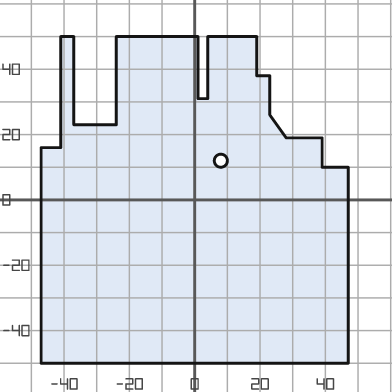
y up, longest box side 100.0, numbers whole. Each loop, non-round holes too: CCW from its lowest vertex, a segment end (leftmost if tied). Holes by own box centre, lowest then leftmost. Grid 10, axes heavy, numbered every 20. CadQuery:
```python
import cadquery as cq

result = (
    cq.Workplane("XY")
    .moveTo(-47.0, -50.0)
    .lineTo(47.0, -50.0)
    .lineTo(47.0, 10.0)
    .lineTo(39.0, 10.0)
    .lineTo(39.0, 19.0)
    .lineTo(28.0, 19.0)
    .lineTo(23.0, 26.0)
    .lineTo(23.0, 38.0)
    .lineTo(19.0, 38.0)
    .lineTo(19.0, 50.0)
    .lineTo(4.0, 50.0)
    .lineTo(4.0, 31.0)
    .lineTo(1.0, 31.0)
    .lineTo(1.0, 50.0)
    .lineTo(-24.0, 50.0)
    .lineTo(-24.0, 23.0)
    .lineTo(-37.0, 23.0)
    .lineTo(-37.0, 50.0)
    .lineTo(-41.0, 50.0)
    .lineTo(-41.0, 16.0)
    .lineTo(-47.0, 16.0)
    .close()
    .moveTo(8.0, 12.0)
    .circle(2.0)
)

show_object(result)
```